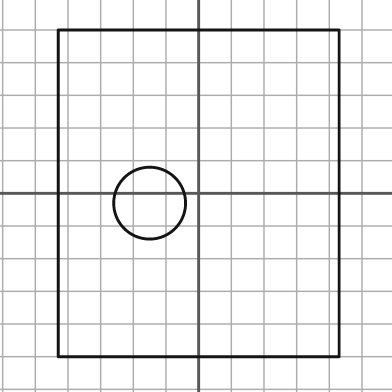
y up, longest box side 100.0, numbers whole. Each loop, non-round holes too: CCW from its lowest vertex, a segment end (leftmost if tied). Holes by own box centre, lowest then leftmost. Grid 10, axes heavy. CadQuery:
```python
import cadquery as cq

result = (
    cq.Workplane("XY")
    .moveTo(-43.0, -50.0)
    .lineTo(43.0, -50.0)
    .lineTo(43.0, 50.0)
    .lineTo(-43.0, 50.0)
    .close()
    .moveTo(-15.0, -3.0)
    .circle(11.0)
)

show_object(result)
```